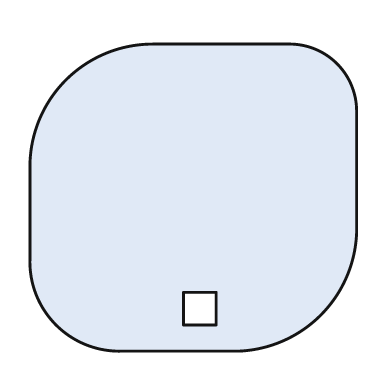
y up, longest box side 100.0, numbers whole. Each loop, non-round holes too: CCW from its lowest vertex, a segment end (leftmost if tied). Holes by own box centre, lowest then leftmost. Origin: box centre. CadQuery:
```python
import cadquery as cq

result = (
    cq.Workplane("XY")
    .moveTo(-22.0, -47.0)
    .lineTo(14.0, -47.0)
    .threePointArc((39.0, -36.0), (50.0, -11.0))
    .lineTo(50.0, 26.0)
    .threePointArc((44.0, 41.0), (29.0, 47.0))
    .lineTo(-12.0, 47.0)
    .threePointArc((-39.0, 36.0), (-50.0, 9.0))
    .lineTo(-50.0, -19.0)
    .threePointArc((-42.0, -39.0), (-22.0, -47.0))
    .close()
    .moveTo(-3.0, -39.0)
    .lineTo(7.0, -39.0)
    .lineTo(7.0, -29.0)
    .lineTo(-3.0, -29.0)
    .close()
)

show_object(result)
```